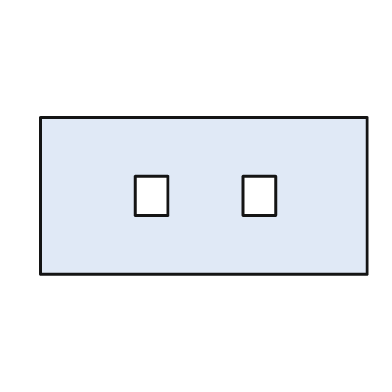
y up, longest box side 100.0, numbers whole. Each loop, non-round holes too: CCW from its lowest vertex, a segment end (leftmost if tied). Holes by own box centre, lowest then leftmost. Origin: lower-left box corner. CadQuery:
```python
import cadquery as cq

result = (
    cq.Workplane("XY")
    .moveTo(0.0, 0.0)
    .lineTo(100.0, 0.0)
    .lineTo(100.0, 48.0)
    .lineTo(0.0, 48.0)
    .close()
    .moveTo(29.0, 18.0)
    .lineTo(39.0, 18.0)
    .lineTo(39.0, 30.0)
    .lineTo(29.0, 30.0)
    .close()
    .moveTo(62.0, 18.0)
    .lineTo(72.0, 18.0)
    .lineTo(72.0, 30.0)
    .lineTo(62.0, 30.0)
    .close()
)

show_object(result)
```